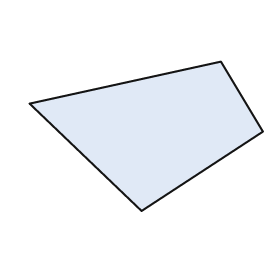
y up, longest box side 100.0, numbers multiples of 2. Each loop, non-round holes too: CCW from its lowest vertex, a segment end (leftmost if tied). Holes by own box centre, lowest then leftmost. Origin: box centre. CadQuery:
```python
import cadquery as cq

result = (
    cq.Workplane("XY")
    .moveTo(-2.0, -32.0)
    .lineTo(50.0, 2.0)
    .lineTo(32.0, 32.0)
    .lineTo(-50.0, 14.0)
    .close()
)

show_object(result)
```